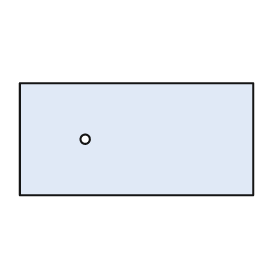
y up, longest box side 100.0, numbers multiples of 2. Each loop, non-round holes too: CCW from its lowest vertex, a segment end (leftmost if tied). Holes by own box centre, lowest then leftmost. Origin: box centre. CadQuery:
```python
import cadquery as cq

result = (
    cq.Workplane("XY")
    .moveTo(-50.0, -24.0)
    .lineTo(50.0, -24.0)
    .lineTo(50.0, 24.0)
    .lineTo(-50.0, 24.0)
    .close()
    .moveTo(-22.0, 0.0)
    .circle(2.0)
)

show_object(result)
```